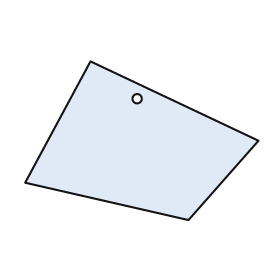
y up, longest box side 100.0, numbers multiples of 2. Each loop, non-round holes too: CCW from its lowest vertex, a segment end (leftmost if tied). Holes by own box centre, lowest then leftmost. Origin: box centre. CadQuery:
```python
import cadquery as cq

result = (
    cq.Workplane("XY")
    .moveTo(20.0, -34.0)
    .lineTo(50.0, 0.0)
    .lineTo(-22.0, 34.0)
    .lineTo(-50.0, -18.0)
    .close()
    .moveTo(-2.0, 18.0)
    .circle(2.0)
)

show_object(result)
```